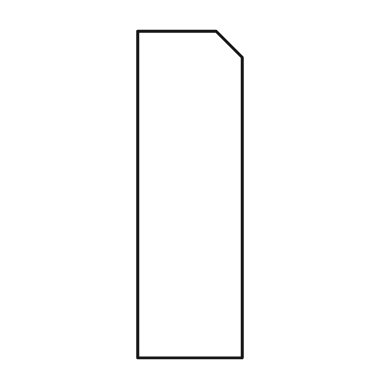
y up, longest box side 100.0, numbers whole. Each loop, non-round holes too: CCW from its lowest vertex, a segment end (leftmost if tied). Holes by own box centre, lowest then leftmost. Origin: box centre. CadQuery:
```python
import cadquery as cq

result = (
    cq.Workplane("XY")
    .moveTo(-16.0, -50.0)
    .lineTo(16.0, -50.0)
    .lineTo(16.0, 42.0)
    .lineTo(8.0, 50.0)
    .lineTo(-16.0, 50.0)
    .close()
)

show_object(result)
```